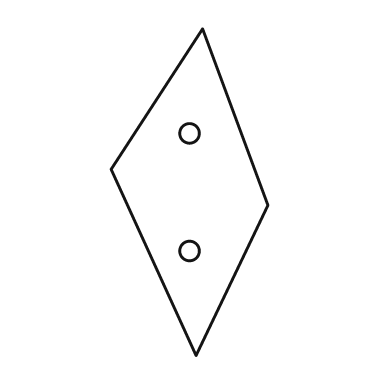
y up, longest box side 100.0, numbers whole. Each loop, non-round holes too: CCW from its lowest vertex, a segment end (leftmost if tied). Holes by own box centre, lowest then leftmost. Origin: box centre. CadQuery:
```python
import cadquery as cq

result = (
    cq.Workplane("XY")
    .moveTo(2.0, -50.0)
    .lineTo(24.0, -4.0)
    .lineTo(4.0, 50.0)
    .lineTo(-24.0, 7.0)
    .close()
    .moveTo(0.0, -18.0)
    .circle(3.0)
    .moveTo(0.0, 18.0)
    .circle(3.0)
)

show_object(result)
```